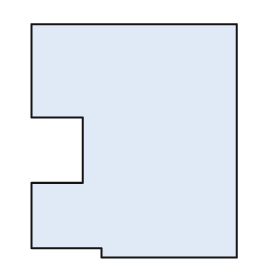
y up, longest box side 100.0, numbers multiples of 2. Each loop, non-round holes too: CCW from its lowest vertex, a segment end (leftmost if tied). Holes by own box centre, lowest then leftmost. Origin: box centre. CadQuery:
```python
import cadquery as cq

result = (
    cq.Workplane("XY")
    .moveTo(-14.0, -50.0)
    .lineTo(44.0, -50.0)
    .lineTo(44.0, 50.0)
    .lineTo(-44.0, 50.0)
    .lineTo(-44.0, 10.0)
    .lineTo(-22.0, 10.0)
    .lineTo(-22.0, -18.0)
    .lineTo(-44.0, -18.0)
    .lineTo(-44.0, -46.0)
    .lineTo(-14.0, -46.0)
    .close()
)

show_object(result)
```